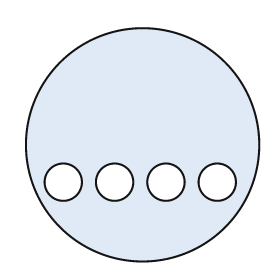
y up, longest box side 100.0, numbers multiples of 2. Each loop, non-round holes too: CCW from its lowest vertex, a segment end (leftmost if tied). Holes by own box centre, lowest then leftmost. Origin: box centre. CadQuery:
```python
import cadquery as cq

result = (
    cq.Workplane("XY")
    .moveTo(0.0, 0.0)
    .circle(50.0)
    .moveTo(-34.0, -16.0)
    .circle(8.0)
    .moveTo(-12.0, -16.0)
    .circle(8.0)
    .moveTo(10.0, -16.0)
    .circle(8.0)
    .moveTo(32.0, -16.0)
    .circle(8.0)
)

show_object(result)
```